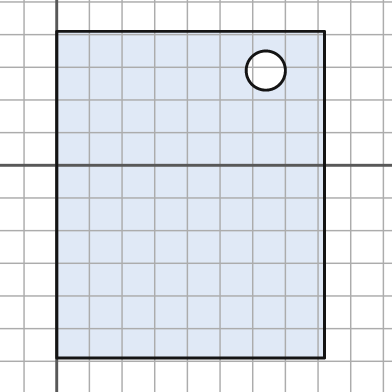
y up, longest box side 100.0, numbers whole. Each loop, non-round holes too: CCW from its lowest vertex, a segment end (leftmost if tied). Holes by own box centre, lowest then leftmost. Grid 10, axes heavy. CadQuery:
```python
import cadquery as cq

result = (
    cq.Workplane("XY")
    .moveTo(0.0, -59.0)
    .lineTo(82.0, -59.0)
    .lineTo(82.0, 41.0)
    .lineTo(0.0, 41.0)
    .close()
    .moveTo(64.0, 29.0)
    .circle(6.0)
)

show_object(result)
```